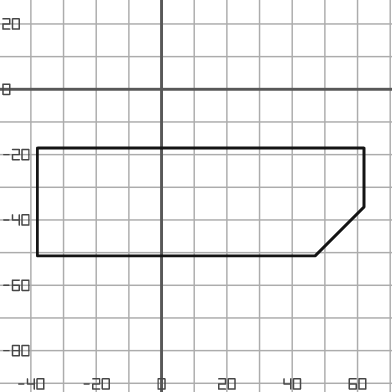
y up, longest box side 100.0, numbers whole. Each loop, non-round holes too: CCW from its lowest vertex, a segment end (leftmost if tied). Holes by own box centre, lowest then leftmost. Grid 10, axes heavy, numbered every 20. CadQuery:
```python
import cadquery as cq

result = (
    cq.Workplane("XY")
    .moveTo(-38.0, -51.0)
    .lineTo(47.0, -51.0)
    .lineTo(62.0, -36.0)
    .lineTo(62.0, -18.0)
    .lineTo(-38.0, -18.0)
    .close()
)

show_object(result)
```